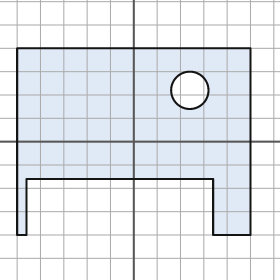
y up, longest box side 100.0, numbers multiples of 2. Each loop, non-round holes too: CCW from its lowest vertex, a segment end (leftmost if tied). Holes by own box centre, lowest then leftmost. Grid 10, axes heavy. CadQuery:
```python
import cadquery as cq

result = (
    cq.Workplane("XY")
    .moveTo(-50.0, -40.0)
    .lineTo(-46.0, -40.0)
    .lineTo(-46.0, -16.0)
    .lineTo(34.0, -16.0)
    .lineTo(34.0, -40.0)
    .lineTo(50.0, -40.0)
    .lineTo(50.0, 40.0)
    .lineTo(-50.0, 40.0)
    .close()
    .moveTo(24.0, 22.0)
    .circle(8.0)
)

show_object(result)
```